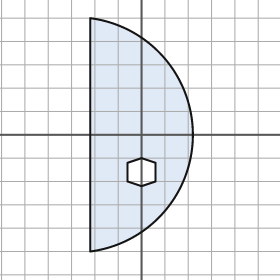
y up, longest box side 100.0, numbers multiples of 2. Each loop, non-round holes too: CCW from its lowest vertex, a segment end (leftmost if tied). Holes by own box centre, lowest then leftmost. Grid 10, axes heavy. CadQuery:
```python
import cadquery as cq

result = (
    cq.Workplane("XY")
    .moveTo(-22.0, -50.0)
    .threePointArc((22.0, 0.0), (-22.0, 50.0))
    .close()
    .moveTo(0.0, -22.0)
    .lineTo(6.0, -20.0)
    .lineTo(6.0, -12.0)
    .lineTo(0.0, -10.0)
    .lineTo(-6.0, -12.0)
    .lineTo(-6.0, -20.0)
    .close()
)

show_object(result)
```